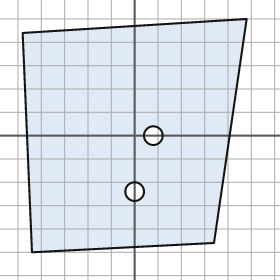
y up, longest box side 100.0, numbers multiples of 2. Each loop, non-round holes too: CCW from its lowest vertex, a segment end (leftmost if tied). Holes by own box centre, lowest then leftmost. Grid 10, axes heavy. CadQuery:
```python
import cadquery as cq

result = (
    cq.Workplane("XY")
    .moveTo(-44.0, -50.0)
    .lineTo(34.0, -46.0)
    .lineTo(48.0, 50.0)
    .lineTo(-48.0, 44.0)
    .close()
    .moveTo(0.0, -24.0)
    .circle(4.0)
    .moveTo(8.0, 0.0)
    .circle(4.0)
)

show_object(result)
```